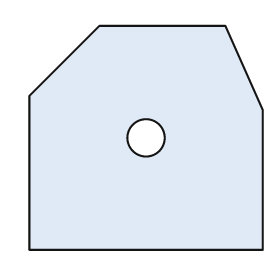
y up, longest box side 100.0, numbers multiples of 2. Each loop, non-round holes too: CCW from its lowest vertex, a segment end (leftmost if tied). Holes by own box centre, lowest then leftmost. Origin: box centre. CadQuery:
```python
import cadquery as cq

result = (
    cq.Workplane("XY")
    .moveTo(-50.0, -48.0)
    .lineTo(50.0, -48.0)
    .lineTo(50.0, 12.0)
    .lineTo(34.0, 48.0)
    .lineTo(-20.0, 48.0)
    .lineTo(-50.0, 18.0)
    .close()
    .moveTo(0.0, 0.0)
    .circle(8.0)
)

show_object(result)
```